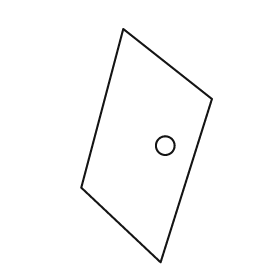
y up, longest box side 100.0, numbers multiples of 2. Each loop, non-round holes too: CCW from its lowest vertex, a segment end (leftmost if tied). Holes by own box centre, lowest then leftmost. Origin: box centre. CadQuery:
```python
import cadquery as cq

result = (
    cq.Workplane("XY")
    .moveTo(6.0, -50.0)
    .lineTo(28.0, 20.0)
    .lineTo(-10.0, 50.0)
    .lineTo(-28.0, -18.0)
    .close()
    .moveTo(8.0, 0.0)
    .circle(4.0)
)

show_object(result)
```